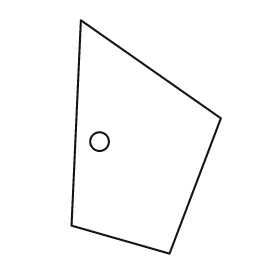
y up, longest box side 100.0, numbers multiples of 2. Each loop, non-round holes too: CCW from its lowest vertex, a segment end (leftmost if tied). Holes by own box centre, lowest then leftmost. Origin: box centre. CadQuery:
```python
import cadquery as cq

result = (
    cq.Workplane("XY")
    .moveTo(10.0, -50.0)
    .lineTo(32.0, 8.0)
    .lineTo(-28.0, 50.0)
    .lineTo(-32.0, -38.0)
    .close()
    .moveTo(-20.0, -2.0)
    .circle(4.0)
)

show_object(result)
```